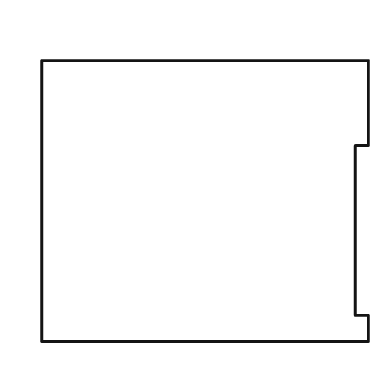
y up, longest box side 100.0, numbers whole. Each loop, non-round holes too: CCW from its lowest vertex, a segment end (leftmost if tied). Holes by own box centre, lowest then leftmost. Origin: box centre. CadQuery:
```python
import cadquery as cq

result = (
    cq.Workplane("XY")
    .moveTo(-50.0, -43.0)
    .lineTo(50.0, -43.0)
    .lineTo(50.0, -35.0)
    .lineTo(46.0, -35.0)
    .lineTo(46.0, 17.0)
    .lineTo(50.0, 17.0)
    .lineTo(50.0, 43.0)
    .lineTo(-50.0, 43.0)
    .close()
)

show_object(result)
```